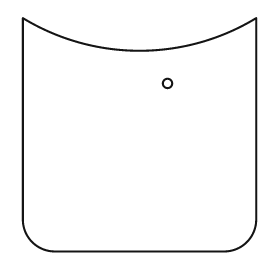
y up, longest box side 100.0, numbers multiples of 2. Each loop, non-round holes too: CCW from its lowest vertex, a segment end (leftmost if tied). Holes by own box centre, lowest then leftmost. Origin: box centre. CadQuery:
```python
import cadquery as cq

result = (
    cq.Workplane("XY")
    .moveTo(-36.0, -50.0)
    .lineTo(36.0, -50.0)
    .threePointArc((46.0, -46.0), (50.0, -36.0))
    .lineTo(50.0, 50.0)
    .threePointArc((0.0, 36.0), (-50.0, 50.0))
    .lineTo(-50.0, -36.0)
    .threePointArc((-46.0, -46.0), (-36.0, -50.0))
    .close()
    .moveTo(12.0, 22.0)
    .circle(2.0)
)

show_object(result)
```